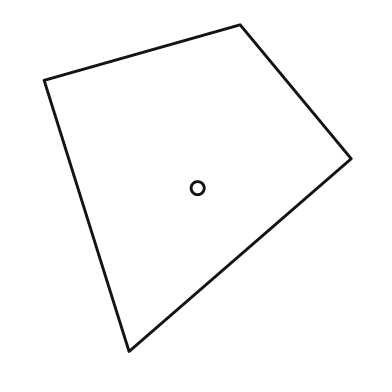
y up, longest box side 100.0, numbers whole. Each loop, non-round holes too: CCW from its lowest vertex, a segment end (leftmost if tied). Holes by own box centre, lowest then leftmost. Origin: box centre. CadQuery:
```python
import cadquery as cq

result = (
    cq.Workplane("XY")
    .moveTo(-21.0, -50.0)
    .lineTo(47.0, 9.0)
    .lineTo(13.0, 50.0)
    .lineTo(-47.0, 33.0)
    .close()
    .moveTo(0.0, 0.0)
    .circle(2.0)
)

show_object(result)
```